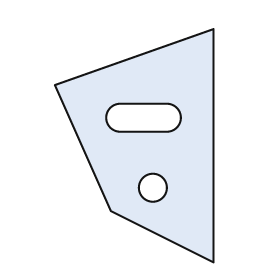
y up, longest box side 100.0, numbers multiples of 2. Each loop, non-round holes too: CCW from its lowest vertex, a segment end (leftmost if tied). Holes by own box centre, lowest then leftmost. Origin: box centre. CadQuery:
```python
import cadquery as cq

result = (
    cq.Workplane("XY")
    .moveTo(34.0, -50.0)
    .lineTo(34.0, 50.0)
    .lineTo(-34.0, 26.0)
    .lineTo(-10.0, -28.0)
    .close()
    .moveTo(8.0, -18.0)
    .circle(6.0)
    .moveTo(-6.0, 6.0)
    .lineTo(14.0, 6.0)
    .threePointArc((20.0, 12.0), (14.0, 18.0))
    .lineTo(-6.0, 18.0)
    .threePointArc((-12.0, 12.0), (-6.0, 6.0))
    .close()
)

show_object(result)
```